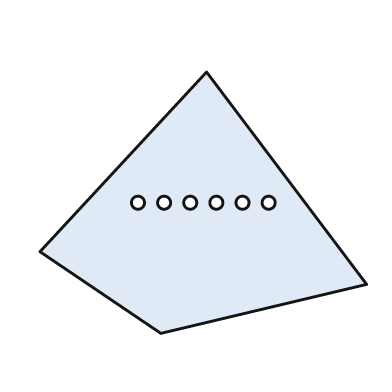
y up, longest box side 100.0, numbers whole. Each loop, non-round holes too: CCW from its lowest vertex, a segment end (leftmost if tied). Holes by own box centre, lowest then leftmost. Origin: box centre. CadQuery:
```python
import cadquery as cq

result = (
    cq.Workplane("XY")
    .moveTo(-13.0, -40.0)
    .lineTo(50.0, -25.0)
    .lineTo(1.0, 40.0)
    .lineTo(-50.0, -15.0)
    .close()
    .moveTo(-20.0, 0.0)
    .circle(2.0)
    .moveTo(-12.0, 0.0)
    .circle(2.0)
    .moveTo(-4.0, 0.0)
    .circle(2.0)
    .moveTo(4.0, 0.0)
    .circle(2.0)
    .moveTo(12.0, 0.0)
    .circle(2.0)
    .moveTo(20.0, 0.0)
    .circle(2.0)
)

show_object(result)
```